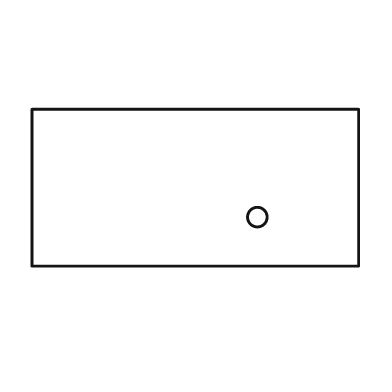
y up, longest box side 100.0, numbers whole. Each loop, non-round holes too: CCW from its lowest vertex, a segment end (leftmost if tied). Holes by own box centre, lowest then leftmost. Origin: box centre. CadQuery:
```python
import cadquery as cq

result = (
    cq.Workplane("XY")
    .moveTo(-50.0, -24.0)
    .lineTo(50.0, -24.0)
    .lineTo(50.0, 24.0)
    .lineTo(-50.0, 24.0)
    .close()
    .moveTo(19.0, -9.0)
    .circle(3.0)
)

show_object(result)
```